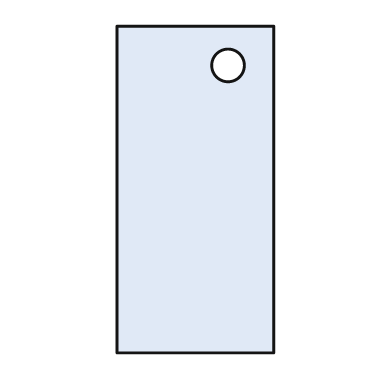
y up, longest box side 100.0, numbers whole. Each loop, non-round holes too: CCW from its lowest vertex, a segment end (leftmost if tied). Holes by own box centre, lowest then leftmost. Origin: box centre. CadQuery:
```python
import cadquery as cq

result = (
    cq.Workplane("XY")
    .moveTo(-24.0, -50.0)
    .lineTo(24.0, -50.0)
    .lineTo(24.0, 50.0)
    .lineTo(-24.0, 50.0)
    .close()
    .moveTo(10.0, 38.0)
    .circle(5.0)
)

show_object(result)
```